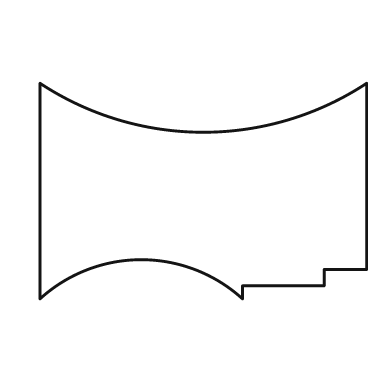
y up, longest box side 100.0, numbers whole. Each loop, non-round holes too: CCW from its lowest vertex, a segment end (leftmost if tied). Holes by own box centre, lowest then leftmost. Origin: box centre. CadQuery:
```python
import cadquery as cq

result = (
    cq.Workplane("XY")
    .moveTo(-50.0, -33.0)
    .threePointArc((-19.0, -21.0), (12.0, -33.0))
    .lineTo(12.0, -29.0)
    .lineTo(37.0, -29.0)
    .lineTo(37.0, -24.0)
    .lineTo(50.0, -24.0)
    .lineTo(50.0, 33.0)
    .threePointArc((0.0, 18.0), (-50.0, 33.0))
    .close()
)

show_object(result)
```